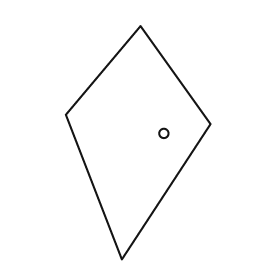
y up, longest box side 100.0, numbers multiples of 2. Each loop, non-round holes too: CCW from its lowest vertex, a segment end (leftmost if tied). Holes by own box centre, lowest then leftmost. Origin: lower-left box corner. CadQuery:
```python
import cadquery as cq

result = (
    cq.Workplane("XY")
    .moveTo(24.0, 0.0)
    .lineTo(62.0, 58.0)
    .lineTo(32.0, 100.0)
    .lineTo(0.0, 62.0)
    .close()
    .moveTo(42.0, 54.0)
    .circle(2.0)
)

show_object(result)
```